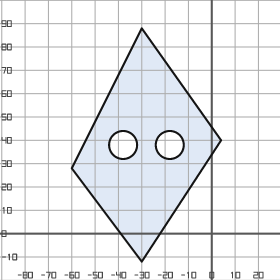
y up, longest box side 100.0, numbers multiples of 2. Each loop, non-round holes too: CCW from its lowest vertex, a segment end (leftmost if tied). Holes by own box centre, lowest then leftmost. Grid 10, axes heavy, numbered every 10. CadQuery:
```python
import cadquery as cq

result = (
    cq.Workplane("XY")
    .moveTo(-30.0, -12.0)
    .lineTo(4.0, 40.0)
    .lineTo(-30.0, 88.0)
    .lineTo(-60.0, 28.0)
    .close()
    .moveTo(-38.0, 38.0)
    .circle(6.0)
    .moveTo(-18.0, 38.0)
    .circle(6.0)
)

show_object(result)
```